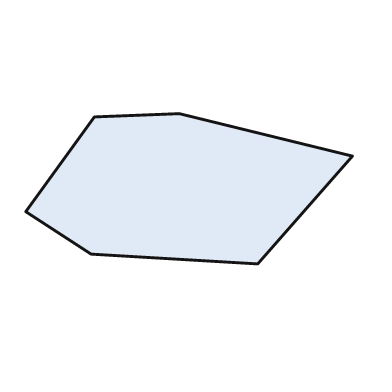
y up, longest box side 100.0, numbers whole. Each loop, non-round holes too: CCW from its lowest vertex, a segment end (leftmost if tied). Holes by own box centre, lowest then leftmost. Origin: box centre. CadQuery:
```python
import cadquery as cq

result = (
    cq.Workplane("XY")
    .moveTo(21.0, -23.0)
    .lineTo(50.0, 10.0)
    .lineTo(-3.0, 23.0)
    .lineTo(-29.0, 22.0)
    .lineTo(-50.0, -7.0)
    .lineTo(-30.0, -20.0)
    .close()
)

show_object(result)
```